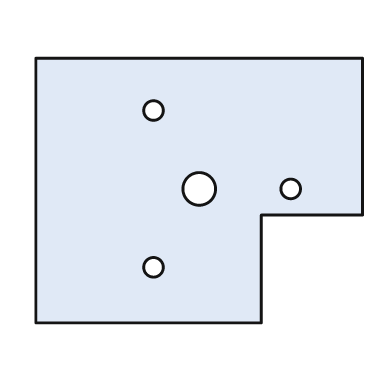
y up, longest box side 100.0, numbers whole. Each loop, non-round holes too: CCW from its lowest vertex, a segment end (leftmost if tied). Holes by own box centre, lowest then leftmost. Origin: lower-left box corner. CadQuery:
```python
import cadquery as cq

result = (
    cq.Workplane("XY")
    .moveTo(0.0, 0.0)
    .lineTo(69.0, 0.0)
    .lineTo(69.0, 33.0)
    .lineTo(100.0, 33.0)
    .lineTo(100.0, 81.0)
    .lineTo(0.0, 81.0)
    .close()
    .moveTo(36.0, 17.0)
    .circle(3.0)
    .moveTo(50.0, 41.0)
    .circle(5.0)
    .moveTo(78.0, 41.0)
    .circle(3.0)
    .moveTo(36.0, 65.0)
    .circle(3.0)
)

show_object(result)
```